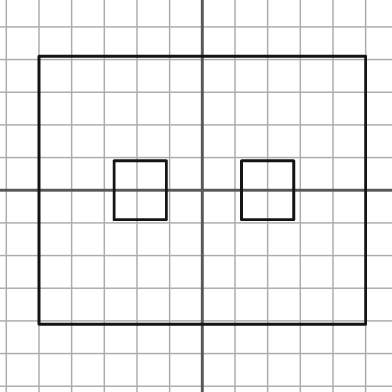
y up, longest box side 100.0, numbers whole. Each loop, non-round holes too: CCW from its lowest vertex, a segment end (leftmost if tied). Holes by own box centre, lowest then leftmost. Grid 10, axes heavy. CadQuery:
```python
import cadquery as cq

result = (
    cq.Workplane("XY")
    .moveTo(-50.0, -41.0)
    .lineTo(50.0, -41.0)
    .lineTo(50.0, 41.0)
    .lineTo(-50.0, 41.0)
    .close()
    .moveTo(-27.0, -9.0)
    .lineTo(-11.0, -9.0)
    .lineTo(-11.0, 9.0)
    .lineTo(-27.0, 9.0)
    .close()
    .moveTo(12.0, -9.0)
    .lineTo(28.0, -9.0)
    .lineTo(28.0, 9.0)
    .lineTo(12.0, 9.0)
    .close()
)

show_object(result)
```